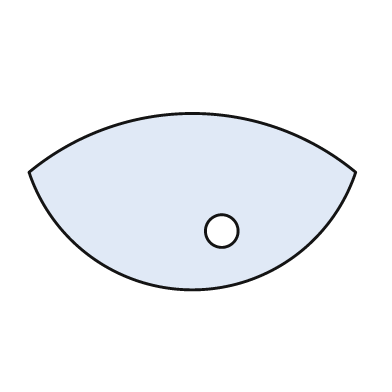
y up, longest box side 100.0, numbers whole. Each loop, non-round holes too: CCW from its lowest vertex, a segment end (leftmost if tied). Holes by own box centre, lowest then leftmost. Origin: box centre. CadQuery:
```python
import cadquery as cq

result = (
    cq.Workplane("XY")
    .moveTo(-50.0, 9.0)
    .threePointArc((0.0, -27.0), (50.0, 9.0))
    .threePointArc((0.0, 27.0), (-50.0, 9.0))
    .close()
    .moveTo(9.0, -9.0)
    .circle(5.0)
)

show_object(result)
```